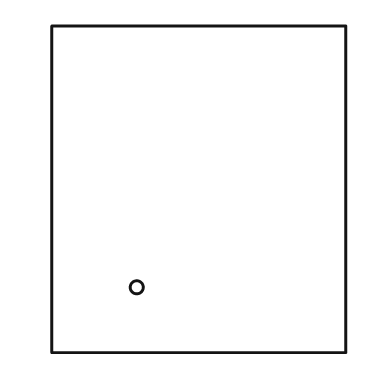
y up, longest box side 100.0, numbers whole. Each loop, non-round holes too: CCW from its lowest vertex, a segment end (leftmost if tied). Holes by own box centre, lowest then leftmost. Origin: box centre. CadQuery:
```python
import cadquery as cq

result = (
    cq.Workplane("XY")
    .moveTo(-45.0, -50.0)
    .lineTo(45.0, -50.0)
    .lineTo(45.0, 50.0)
    .lineTo(-45.0, 50.0)
    .close()
    .moveTo(-19.0, -30.0)
    .circle(2.0)
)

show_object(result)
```